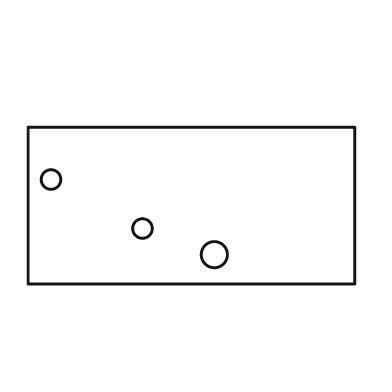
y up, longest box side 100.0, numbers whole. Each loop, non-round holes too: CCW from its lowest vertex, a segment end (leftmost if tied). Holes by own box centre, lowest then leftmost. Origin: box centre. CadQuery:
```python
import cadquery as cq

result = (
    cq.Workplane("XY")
    .moveTo(-50.0, -24.0)
    .lineTo(50.0, -24.0)
    .lineTo(50.0, 24.0)
    .lineTo(-50.0, 24.0)
    .close()
    .moveTo(7.0, -15.0)
    .circle(4.0)
    .moveTo(-15.0, -7.0)
    .circle(3.0)
    .moveTo(-43.0, 8.0)
    .circle(3.0)
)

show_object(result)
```